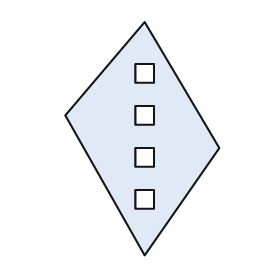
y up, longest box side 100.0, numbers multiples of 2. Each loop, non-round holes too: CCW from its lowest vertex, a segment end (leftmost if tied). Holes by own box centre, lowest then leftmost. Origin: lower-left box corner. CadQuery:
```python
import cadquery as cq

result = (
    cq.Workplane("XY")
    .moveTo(34.0, 0.0)
    .lineTo(66.0, 46.0)
    .lineTo(34.0, 100.0)
    .lineTo(0.0, 60.0)
    .close()
    .moveTo(30.0, 20.0)
    .lineTo(38.0, 20.0)
    .lineTo(38.0, 28.0)
    .lineTo(30.0, 28.0)
    .close()
    .moveTo(30.0, 38.0)
    .lineTo(38.0, 38.0)
    .lineTo(38.0, 46.0)
    .lineTo(30.0, 46.0)
    .close()
    .moveTo(30.0, 56.0)
    .lineTo(38.0, 56.0)
    .lineTo(38.0, 64.0)
    .lineTo(30.0, 64.0)
    .close()
    .moveTo(30.0, 74.0)
    .lineTo(38.0, 74.0)
    .lineTo(38.0, 82.0)
    .lineTo(30.0, 82.0)
    .close()
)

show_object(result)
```